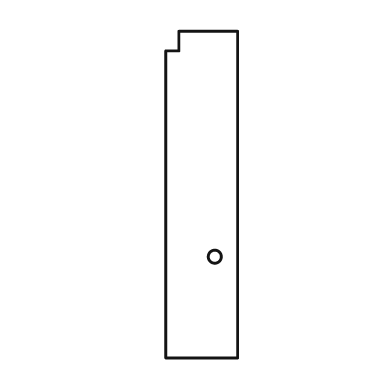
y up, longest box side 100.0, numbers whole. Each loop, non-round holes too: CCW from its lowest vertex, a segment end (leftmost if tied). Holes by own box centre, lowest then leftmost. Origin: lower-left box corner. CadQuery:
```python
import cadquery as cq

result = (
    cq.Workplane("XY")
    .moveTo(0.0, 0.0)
    .lineTo(22.0, 0.0)
    .lineTo(22.0, 100.0)
    .lineTo(4.0, 100.0)
    .lineTo(4.0, 94.0)
    .lineTo(0.0, 94.0)
    .close()
    .moveTo(15.0, 31.0)
    .circle(2.0)
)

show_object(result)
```